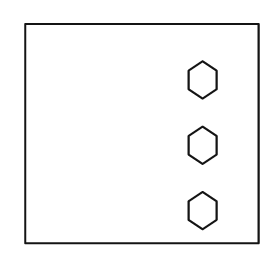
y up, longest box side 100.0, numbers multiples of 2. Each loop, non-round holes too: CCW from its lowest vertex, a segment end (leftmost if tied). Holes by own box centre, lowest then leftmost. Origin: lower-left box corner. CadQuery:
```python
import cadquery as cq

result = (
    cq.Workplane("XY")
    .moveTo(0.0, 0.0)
    .lineTo(100.0, 0.0)
    .lineTo(100.0, 94.0)
    .lineTo(0.0, 94.0)
    .close()
    .moveTo(76.0, 6.0)
    .lineTo(82.0, 10.0)
    .lineTo(82.0, 18.0)
    .lineTo(76.0, 22.0)
    .lineTo(70.0, 18.0)
    .lineTo(70.0, 10.0)
    .close()
    .moveTo(76.0, 34.0)
    .lineTo(82.0, 38.0)
    .lineTo(82.0, 46.0)
    .lineTo(76.0, 50.0)
    .lineTo(70.0, 46.0)
    .lineTo(70.0, 38.0)
    .close()
    .moveTo(76.0, 62.0)
    .lineTo(82.0, 66.0)
    .lineTo(82.0, 74.0)
    .lineTo(76.0, 78.0)
    .lineTo(70.0, 74.0)
    .lineTo(70.0, 66.0)
    .close()
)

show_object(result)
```